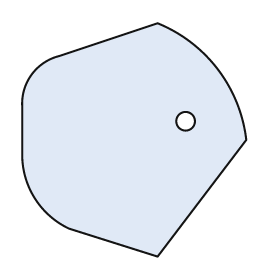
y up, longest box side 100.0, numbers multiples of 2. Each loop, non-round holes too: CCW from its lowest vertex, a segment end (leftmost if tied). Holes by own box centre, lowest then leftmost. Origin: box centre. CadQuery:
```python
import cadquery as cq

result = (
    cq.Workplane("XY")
    .moveTo(10.0, -50.0)
    .lineTo(48.0, 0.0)
    .threePointArc((36.0, 30.0), (10.0, 50.0))
    .lineTo(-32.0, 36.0)
    .threePointArc((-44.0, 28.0), (-48.0, 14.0))
    .lineTo(-48.0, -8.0)
    .threePointArc((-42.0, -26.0), (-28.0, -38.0))
    .close()
    .moveTo(22.0, 8.0)
    .circle(4.0)
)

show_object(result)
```